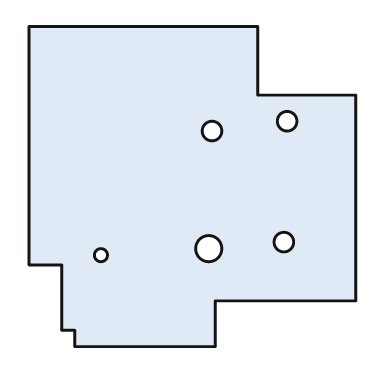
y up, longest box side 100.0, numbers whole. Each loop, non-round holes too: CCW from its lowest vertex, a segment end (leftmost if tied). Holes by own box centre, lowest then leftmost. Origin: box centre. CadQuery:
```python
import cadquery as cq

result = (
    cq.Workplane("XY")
    .moveTo(-36.0, -49.0)
    .lineTo(7.0, -49.0)
    .lineTo(7.0, -35.0)
    .lineTo(50.0, -35.0)
    .lineTo(50.0, 28.0)
    .lineTo(20.0, 28.0)
    .lineTo(20.0, 49.0)
    .lineTo(-50.0, 49.0)
    .lineTo(-50.0, -24.0)
    .lineTo(-40.0, -24.0)
    .lineTo(-40.0, -44.0)
    .lineTo(-36.0, -44.0)
    .close()
    .moveTo(-28.0, -21.0)
    .circle(2.0)
    .moveTo(5.0, -19.0)
    .circle(4.0)
    .moveTo(28.0, -17.0)
    .circle(3.0)
    .moveTo(6.0, 17.0)
    .circle(3.0)
    .moveTo(29.0, 20.0)
    .circle(3.0)
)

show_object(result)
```